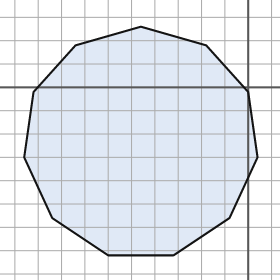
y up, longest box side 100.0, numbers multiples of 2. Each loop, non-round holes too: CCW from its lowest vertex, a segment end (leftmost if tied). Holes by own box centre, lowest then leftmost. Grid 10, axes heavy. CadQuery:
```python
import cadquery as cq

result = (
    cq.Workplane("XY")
    .moveTo(-60.0, -72.0)
    .lineTo(-32.0, -72.0)
    .lineTo(-8.0, -56.0)
    .lineTo(4.0, -30.0)
    .lineTo(0.0, -2.0)
    .lineTo(-18.0, 18.0)
    .lineTo(-46.0, 26.0)
    .lineTo(-74.0, 18.0)
    .lineTo(-92.0, -2.0)
    .lineTo(-96.0, -30.0)
    .lineTo(-84.0, -56.0)
    .close()
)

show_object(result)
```